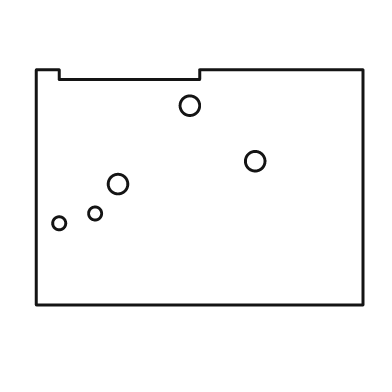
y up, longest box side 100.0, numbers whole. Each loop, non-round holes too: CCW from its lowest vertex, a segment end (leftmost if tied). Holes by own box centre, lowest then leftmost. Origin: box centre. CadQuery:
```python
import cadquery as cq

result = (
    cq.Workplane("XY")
    .moveTo(-50.0, -36.0)
    .lineTo(50.0, -36.0)
    .lineTo(50.0, 36.0)
    .lineTo(0.0, 36.0)
    .lineTo(0.0, 33.0)
    .lineTo(-43.0, 33.0)
    .lineTo(-43.0, 36.0)
    .lineTo(-50.0, 36.0)
    .close()
    .moveTo(-43.0, -11.0)
    .circle(2.0)
    .moveTo(-32.0, -8.0)
    .circle(2.0)
    .moveTo(-25.0, 1.0)
    .circle(3.0)
    .moveTo(17.0, 8.0)
    .circle(3.0)
    .moveTo(-3.0, 25.0)
    .circle(3.0)
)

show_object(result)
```